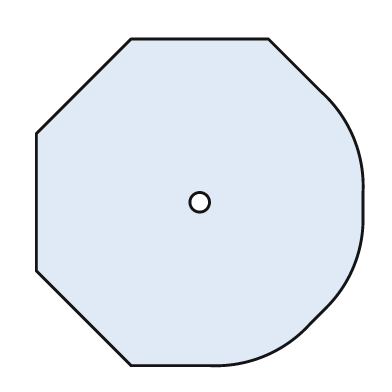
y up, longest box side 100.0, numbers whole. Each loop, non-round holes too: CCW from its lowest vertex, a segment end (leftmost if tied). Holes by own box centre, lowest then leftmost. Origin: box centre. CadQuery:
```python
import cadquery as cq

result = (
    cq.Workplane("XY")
    .moveTo(-21.0, -50.0)
    .lineTo(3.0, -50.0)
    .threePointArc((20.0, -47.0), (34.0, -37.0))
    .lineTo(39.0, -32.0)
    .threePointArc((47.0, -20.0), (50.0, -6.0))
    .lineTo(50.0, 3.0)
    .threePointArc((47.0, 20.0), (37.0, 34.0))
    .lineTo(21.0, 50.0)
    .lineTo(-21.0, 50.0)
    .lineTo(-50.0, 21.0)
    .lineTo(-50.0, -21.0)
    .close()
    .moveTo(0.0, 0.0)
    .circle(3.0)
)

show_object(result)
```